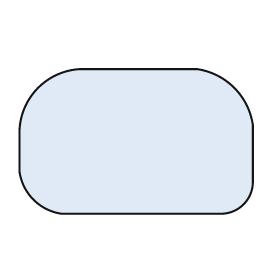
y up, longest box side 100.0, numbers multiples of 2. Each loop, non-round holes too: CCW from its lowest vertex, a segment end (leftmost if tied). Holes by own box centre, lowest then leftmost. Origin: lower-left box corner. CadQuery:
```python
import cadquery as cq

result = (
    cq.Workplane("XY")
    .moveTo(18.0, 0.0)
    .lineTo(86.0, 0.0)
    .threePointArc((96.0, 4.0), (100.0, 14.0))
    .lineTo(100.0, 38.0)
    .threePointArc((92.0, 54.0), (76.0, 62.0))
    .lineTo(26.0, 62.0)
    .threePointArc((8.0, 54.0), (0.0, 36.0))
    .lineTo(0.0, 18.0)
    .threePointArc((6.0, 6.0), (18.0, 0.0))
    .close()
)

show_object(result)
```